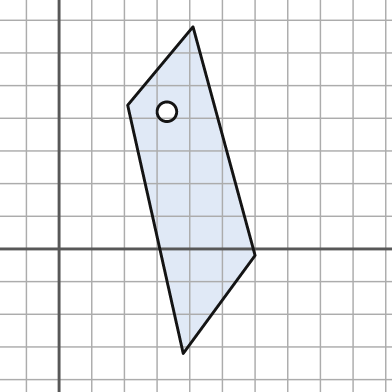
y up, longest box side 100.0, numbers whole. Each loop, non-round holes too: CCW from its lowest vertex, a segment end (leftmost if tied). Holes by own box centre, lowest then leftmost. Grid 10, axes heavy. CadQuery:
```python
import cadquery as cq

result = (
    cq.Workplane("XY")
    .moveTo(38.0, -32.0)
    .lineTo(60.0, -2.0)
    .lineTo(41.0, 68.0)
    .lineTo(21.0, 44.0)
    .close()
    .moveTo(33.0, 42.0)
    .circle(3.0)
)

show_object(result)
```